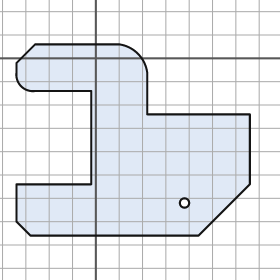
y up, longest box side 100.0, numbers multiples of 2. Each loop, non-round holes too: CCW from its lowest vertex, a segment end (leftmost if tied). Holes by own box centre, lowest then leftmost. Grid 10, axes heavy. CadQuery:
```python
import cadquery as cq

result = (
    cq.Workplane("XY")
    .moveTo(-28.0, -76.0)
    .lineTo(44.0, -76.0)
    .lineTo(66.0, -54.0)
    .lineTo(66.0, -24.0)
    .lineTo(22.0, -24.0)
    .lineTo(22.0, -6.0)
    .threePointArc((18.0, 2.0), (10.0, 6.0))
    .lineTo(-26.0, 6.0)
    .lineTo(-34.0, -2.0)
    .lineTo(-34.0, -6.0)
    .threePointArc((-32.0, -12.0), (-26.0, -14.0))
    .lineTo(-2.0, -14.0)
    .lineTo(-2.0, -54.0)
    .lineTo(-34.0, -54.0)
    .lineTo(-34.0, -70.0)
    .close()
    .moveTo(38.0, -62.0)
    .circle(2.0)
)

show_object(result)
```